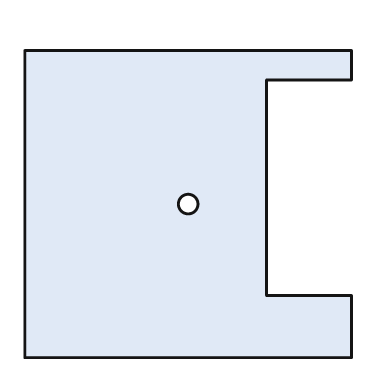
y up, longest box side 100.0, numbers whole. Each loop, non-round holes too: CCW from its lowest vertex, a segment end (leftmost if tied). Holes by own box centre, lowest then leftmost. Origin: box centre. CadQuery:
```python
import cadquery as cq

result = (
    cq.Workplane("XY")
    .moveTo(-50.0, -47.0)
    .lineTo(50.0, -47.0)
    .lineTo(50.0, -28.0)
    .lineTo(24.0, -28.0)
    .lineTo(24.0, 38.0)
    .lineTo(50.0, 38.0)
    .lineTo(50.0, 47.0)
    .lineTo(-50.0, 47.0)
    .close()
    .moveTo(0.0, 0.0)
    .circle(3.0)
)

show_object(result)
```